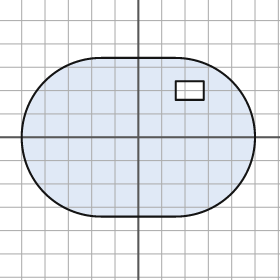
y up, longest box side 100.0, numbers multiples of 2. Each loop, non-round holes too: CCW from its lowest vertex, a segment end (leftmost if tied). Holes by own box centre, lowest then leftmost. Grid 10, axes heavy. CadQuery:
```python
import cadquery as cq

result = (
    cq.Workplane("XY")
    .moveTo(-16.0, -34.0)
    .lineTo(16.0, -34.0)
    .threePointArc((50.0, 0.0), (16.0, 34.0))
    .lineTo(-16.0, 34.0)
    .threePointArc((-50.0, 0.0), (-16.0, -34.0))
    .close()
    .moveTo(16.0, 16.0)
    .lineTo(28.0, 16.0)
    .lineTo(28.0, 24.0)
    .lineTo(16.0, 24.0)
    .close()
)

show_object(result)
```